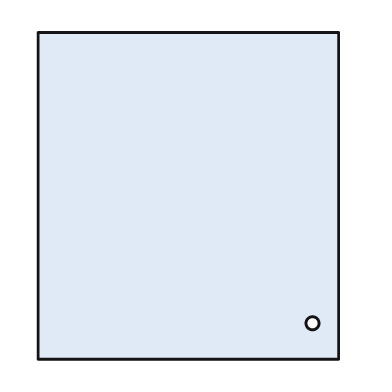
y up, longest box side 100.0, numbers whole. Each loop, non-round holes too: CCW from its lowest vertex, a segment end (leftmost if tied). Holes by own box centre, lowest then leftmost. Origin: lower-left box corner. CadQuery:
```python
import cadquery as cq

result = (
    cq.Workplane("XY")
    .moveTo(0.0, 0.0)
    .lineTo(92.0, 0.0)
    .lineTo(92.0, 100.0)
    .lineTo(0.0, 100.0)
    .close()
    .moveTo(84.0, 11.0)
    .circle(2.0)
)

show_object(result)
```